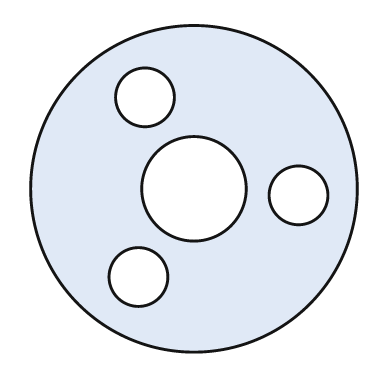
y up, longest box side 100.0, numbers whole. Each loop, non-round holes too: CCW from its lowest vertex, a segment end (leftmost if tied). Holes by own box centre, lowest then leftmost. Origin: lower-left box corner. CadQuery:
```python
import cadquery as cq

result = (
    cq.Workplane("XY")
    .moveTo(50.0, 50.0)
    .circle(50.0)
    .moveTo(33.0, 23.0)
    .circle(9.0)
    .moveTo(82.0, 48.0)
    .circle(9.0)
    .moveTo(50.0, 50.0)
    .circle(16.0)
    .moveTo(35.0, 78.0)
    .circle(9.0)
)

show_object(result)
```